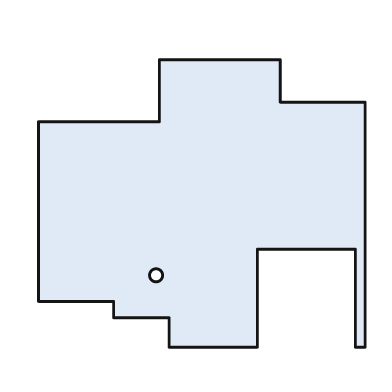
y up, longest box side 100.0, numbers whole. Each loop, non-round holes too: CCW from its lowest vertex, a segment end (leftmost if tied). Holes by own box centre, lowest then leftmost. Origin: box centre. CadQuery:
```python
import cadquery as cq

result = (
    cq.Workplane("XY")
    .moveTo(-10.0, -44.0)
    .lineTo(17.0, -44.0)
    .lineTo(17.0, -14.0)
    .lineTo(47.0, -14.0)
    .lineTo(47.0, -44.0)
    .lineTo(50.0, -44.0)
    .lineTo(50.0, 31.0)
    .lineTo(24.0, 31.0)
    .lineTo(24.0, 44.0)
    .lineTo(-13.0, 44.0)
    .lineTo(-13.0, 25.0)
    .lineTo(-50.0, 25.0)
    .lineTo(-50.0, -30.0)
    .lineTo(-27.0, -30.0)
    .lineTo(-27.0, -35.0)
    .lineTo(-10.0, -35.0)
    .close()
    .moveTo(-14.0, -22.0)
    .circle(2.0)
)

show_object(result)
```